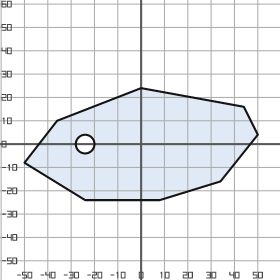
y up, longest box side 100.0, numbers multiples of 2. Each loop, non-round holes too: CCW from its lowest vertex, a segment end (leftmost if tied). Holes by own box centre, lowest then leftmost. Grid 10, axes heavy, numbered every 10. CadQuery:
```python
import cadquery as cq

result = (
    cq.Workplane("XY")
    .moveTo(-24.0, -24.0)
    .lineTo(8.0, -24.0)
    .lineTo(34.0, -16.0)
    .lineTo(50.0, 4.0)
    .lineTo(44.0, 16.0)
    .lineTo(0.0, 24.0)
    .lineTo(-36.0, 10.0)
    .lineTo(-50.0, -8.0)
    .close()
    .moveTo(-24.0, 0.0)
    .circle(4.0)
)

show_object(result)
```